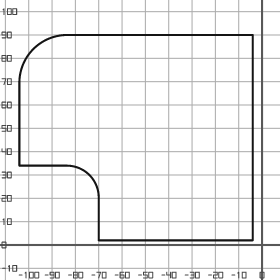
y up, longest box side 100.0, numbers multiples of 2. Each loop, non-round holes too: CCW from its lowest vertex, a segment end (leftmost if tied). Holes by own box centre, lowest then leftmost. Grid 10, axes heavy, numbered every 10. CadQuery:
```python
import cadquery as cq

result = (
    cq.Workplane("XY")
    .moveTo(-70.0, 2.0)
    .lineTo(-4.0, 2.0)
    .lineTo(-4.0, 90.0)
    .lineTo(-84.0, 90.0)
    .threePointArc((-98.0, 84.0), (-104.0, 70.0))
    .lineTo(-104.0, 34.0)
    .lineTo(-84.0, 34.0)
    .threePointArc((-74.0, 30.0), (-70.0, 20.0))
    .close()
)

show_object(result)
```